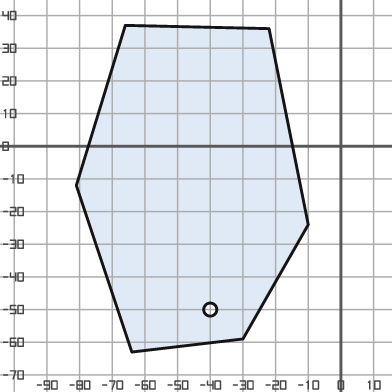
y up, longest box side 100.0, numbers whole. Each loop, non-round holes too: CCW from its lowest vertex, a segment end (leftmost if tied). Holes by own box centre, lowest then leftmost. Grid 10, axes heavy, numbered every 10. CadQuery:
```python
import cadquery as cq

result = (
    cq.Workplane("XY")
    .moveTo(-64.0, -63.0)
    .lineTo(-30.0, -59.0)
    .lineTo(-10.0, -24.0)
    .lineTo(-22.0, 36.0)
    .lineTo(-66.0, 37.0)
    .lineTo(-81.0, -12.0)
    .close()
    .moveTo(-40.0, -50.0)
    .circle(2.0)
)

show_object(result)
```